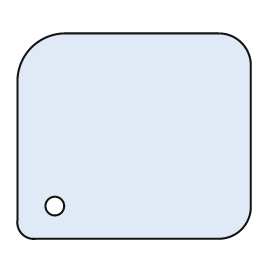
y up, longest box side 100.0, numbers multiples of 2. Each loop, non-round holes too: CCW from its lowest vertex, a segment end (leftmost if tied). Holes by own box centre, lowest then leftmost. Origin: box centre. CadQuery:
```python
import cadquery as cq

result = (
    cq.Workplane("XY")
    .moveTo(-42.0, -44.0)
    .lineTo(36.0, -44.0)
    .threePointArc((46.0, -40.0), (50.0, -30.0))
    .lineTo(50.0, 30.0)
    .threePointArc((46.0, 40.0), (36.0, 44.0))
    .lineTo(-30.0, 44.0)
    .threePointArc((-44.0, 38.0), (-50.0, 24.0))
    .lineTo(-50.0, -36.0)
    .threePointArc((-48.0, -42.0), (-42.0, -44.0))
    .close()
    .moveTo(-34.0, -30.0)
    .circle(4.0)
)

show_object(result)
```